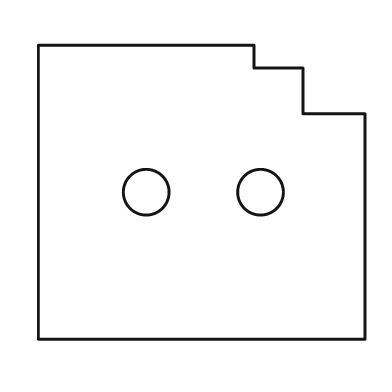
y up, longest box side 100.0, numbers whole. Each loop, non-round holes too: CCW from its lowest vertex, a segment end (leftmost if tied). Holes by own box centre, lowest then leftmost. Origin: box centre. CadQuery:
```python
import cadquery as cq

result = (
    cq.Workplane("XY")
    .moveTo(-50.0, -45.0)
    .lineTo(50.0, -45.0)
    .lineTo(50.0, 24.0)
    .lineTo(31.0, 24.0)
    .lineTo(31.0, 38.0)
    .lineTo(16.0, 38.0)
    .lineTo(16.0, 45.0)
    .lineTo(-50.0, 45.0)
    .close()
    .moveTo(-17.0, 0.0)
    .circle(7.0)
    .moveTo(18.0, 0.0)
    .circle(7.0)
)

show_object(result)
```